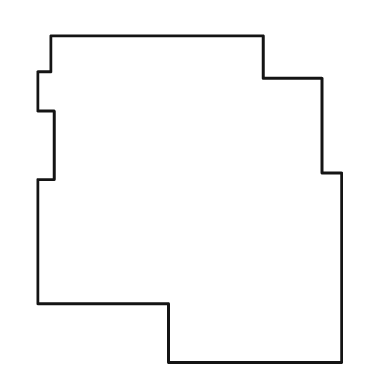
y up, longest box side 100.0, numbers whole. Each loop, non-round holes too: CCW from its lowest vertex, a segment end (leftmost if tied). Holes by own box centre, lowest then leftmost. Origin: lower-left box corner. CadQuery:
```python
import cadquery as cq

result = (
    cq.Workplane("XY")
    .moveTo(40.0, 0.0)
    .lineTo(93.0, 0.0)
    .lineTo(93.0, 58.0)
    .lineTo(87.0, 58.0)
    .lineTo(87.0, 87.0)
    .lineTo(69.0, 87.0)
    .lineTo(69.0, 100.0)
    .lineTo(4.0, 100.0)
    .lineTo(4.0, 89.0)
    .lineTo(0.0, 89.0)
    .lineTo(0.0, 77.0)
    .lineTo(5.0, 77.0)
    .lineTo(5.0, 56.0)
    .lineTo(0.0, 56.0)
    .lineTo(0.0, 18.0)
    .lineTo(40.0, 18.0)
    .close()
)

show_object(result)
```